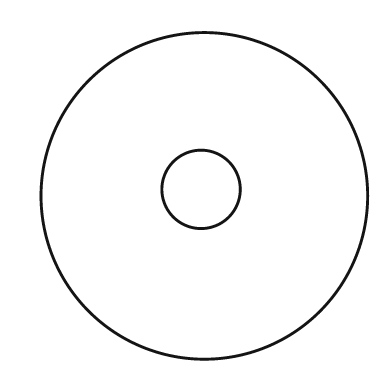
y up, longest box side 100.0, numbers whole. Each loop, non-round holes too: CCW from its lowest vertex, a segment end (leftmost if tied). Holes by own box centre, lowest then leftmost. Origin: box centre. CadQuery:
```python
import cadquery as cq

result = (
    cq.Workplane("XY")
    .moveTo(0.0, 0.0)
    .circle(50.0)
    .moveTo(-1.0, 2.0)
    .circle(12.0)
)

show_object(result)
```